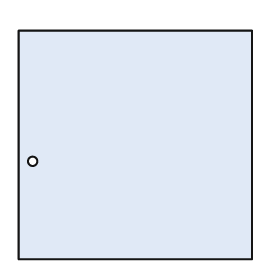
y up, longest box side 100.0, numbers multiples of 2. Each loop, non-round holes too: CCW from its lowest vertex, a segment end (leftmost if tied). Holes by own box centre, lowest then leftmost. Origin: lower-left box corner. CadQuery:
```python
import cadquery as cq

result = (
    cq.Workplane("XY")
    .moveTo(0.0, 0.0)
    .lineTo(100.0, 0.0)
    .lineTo(100.0, 98.0)
    .lineTo(0.0, 98.0)
    .close()
    .moveTo(6.0, 42.0)
    .circle(2.0)
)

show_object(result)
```